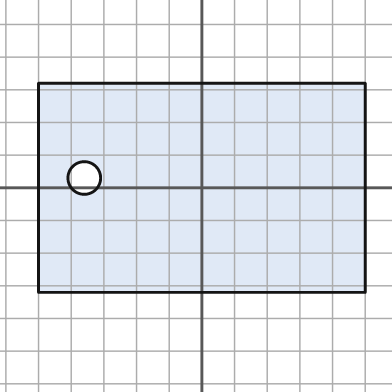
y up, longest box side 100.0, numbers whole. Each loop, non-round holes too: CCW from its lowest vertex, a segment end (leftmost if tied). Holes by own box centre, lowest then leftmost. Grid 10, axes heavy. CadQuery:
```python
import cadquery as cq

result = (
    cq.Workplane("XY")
    .moveTo(-50.0, -32.0)
    .lineTo(50.0, -32.0)
    .lineTo(50.0, 32.0)
    .lineTo(-50.0, 32.0)
    .close()
    .moveTo(-36.0, 3.0)
    .circle(5.0)
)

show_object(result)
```